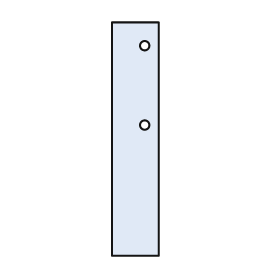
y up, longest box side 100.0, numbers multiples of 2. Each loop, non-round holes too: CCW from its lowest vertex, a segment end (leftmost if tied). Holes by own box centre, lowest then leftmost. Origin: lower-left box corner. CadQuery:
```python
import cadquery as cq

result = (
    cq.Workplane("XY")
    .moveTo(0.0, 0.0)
    .lineTo(20.0, 0.0)
    .lineTo(20.0, 100.0)
    .lineTo(0.0, 100.0)
    .close()
    .moveTo(14.0, 56.0)
    .circle(2.0)
    .moveTo(14.0, 90.0)
    .circle(2.0)
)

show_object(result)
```